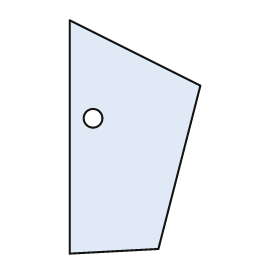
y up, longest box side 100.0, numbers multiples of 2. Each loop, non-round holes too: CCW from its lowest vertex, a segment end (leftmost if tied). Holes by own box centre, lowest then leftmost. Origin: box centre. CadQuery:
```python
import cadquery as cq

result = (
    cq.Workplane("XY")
    .moveTo(-28.0, -50.0)
    .lineTo(10.0, -48.0)
    .lineTo(28.0, 22.0)
    .lineTo(-28.0, 50.0)
    .close()
    .moveTo(-18.0, 8.0)
    .circle(4.0)
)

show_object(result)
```